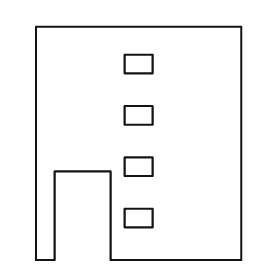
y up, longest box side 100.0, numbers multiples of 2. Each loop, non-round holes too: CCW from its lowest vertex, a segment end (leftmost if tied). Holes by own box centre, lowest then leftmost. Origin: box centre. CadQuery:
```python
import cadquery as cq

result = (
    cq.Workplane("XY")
    .moveTo(-44.0, -50.0)
    .lineTo(-36.0, -50.0)
    .lineTo(-36.0, -12.0)
    .lineTo(-12.0, -12.0)
    .lineTo(-12.0, -50.0)
    .lineTo(44.0, -50.0)
    .lineTo(44.0, 50.0)
    .lineTo(-44.0, 50.0)
    .close()
    .moveTo(-6.0, -36.0)
    .lineTo(6.0, -36.0)
    .lineTo(6.0, -28.0)
    .lineTo(-6.0, -28.0)
    .close()
    .moveTo(-6.0, -14.0)
    .lineTo(6.0, -14.0)
    .lineTo(6.0, -6.0)
    .lineTo(-6.0, -6.0)
    .close()
    .moveTo(-6.0, 8.0)
    .lineTo(6.0, 8.0)
    .lineTo(6.0, 16.0)
    .lineTo(-6.0, 16.0)
    .close()
    .moveTo(-6.0, 30.0)
    .lineTo(6.0, 30.0)
    .lineTo(6.0, 38.0)
    .lineTo(-6.0, 38.0)
    .close()
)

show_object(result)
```